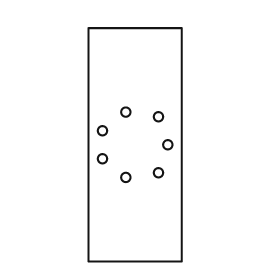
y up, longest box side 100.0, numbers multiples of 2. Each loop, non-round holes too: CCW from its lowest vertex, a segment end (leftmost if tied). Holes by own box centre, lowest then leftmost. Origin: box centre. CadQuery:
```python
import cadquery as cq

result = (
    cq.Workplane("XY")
    .moveTo(-20.0, -50.0)
    .lineTo(20.0, -50.0)
    .lineTo(20.0, 50.0)
    .lineTo(-20.0, 50.0)
    .close()
    .moveTo(-4.0, -14.0)
    .circle(2.0)
    .moveTo(10.0, -12.0)
    .circle(2.0)
    .moveTo(-14.0, -6.0)
    .circle(2.0)
    .moveTo(14.0, 0.0)
    .circle(2.0)
    .moveTo(-14.0, 6.0)
    .circle(2.0)
    .moveTo(10.0, 12.0)
    .circle(2.0)
    .moveTo(-4.0, 14.0)
    .circle(2.0)
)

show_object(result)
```